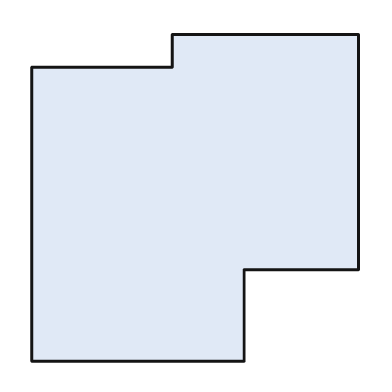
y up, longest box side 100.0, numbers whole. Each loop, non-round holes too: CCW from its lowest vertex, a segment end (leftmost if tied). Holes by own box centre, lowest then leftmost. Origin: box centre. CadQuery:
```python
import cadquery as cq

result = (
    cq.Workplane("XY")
    .moveTo(-50.0, -50.0)
    .lineTo(15.0, -50.0)
    .lineTo(15.0, -22.0)
    .lineTo(50.0, -22.0)
    .lineTo(50.0, 50.0)
    .lineTo(-7.0, 50.0)
    .lineTo(-7.0, 40.0)
    .lineTo(-50.0, 40.0)
    .close()
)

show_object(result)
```